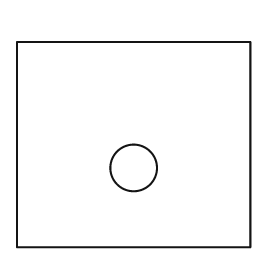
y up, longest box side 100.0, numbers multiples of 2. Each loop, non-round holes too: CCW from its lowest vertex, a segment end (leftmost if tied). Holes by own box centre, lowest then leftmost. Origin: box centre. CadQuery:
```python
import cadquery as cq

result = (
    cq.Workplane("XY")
    .moveTo(-50.0, -44.0)
    .lineTo(50.0, -44.0)
    .lineTo(50.0, 44.0)
    .lineTo(-50.0, 44.0)
    .close()
    .moveTo(0.0, -10.0)
    .circle(10.0)
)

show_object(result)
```